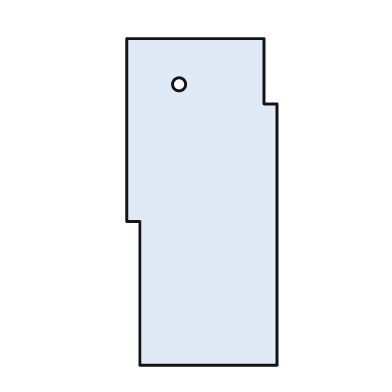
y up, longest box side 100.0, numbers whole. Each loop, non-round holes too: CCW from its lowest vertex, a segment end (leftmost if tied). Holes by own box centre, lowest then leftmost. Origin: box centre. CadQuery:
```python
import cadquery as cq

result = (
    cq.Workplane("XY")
    .moveTo(-19.0, -50.0)
    .lineTo(23.0, -50.0)
    .lineTo(23.0, 30.0)
    .lineTo(19.0, 30.0)
    .lineTo(19.0, 50.0)
    .lineTo(-23.0, 50.0)
    .lineTo(-23.0, -6.0)
    .lineTo(-19.0, -6.0)
    .close()
    .moveTo(-7.0, 36.0)
    .circle(2.0)
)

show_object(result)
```